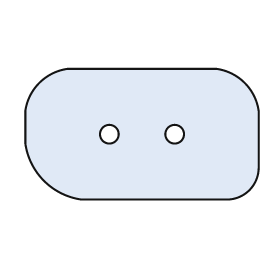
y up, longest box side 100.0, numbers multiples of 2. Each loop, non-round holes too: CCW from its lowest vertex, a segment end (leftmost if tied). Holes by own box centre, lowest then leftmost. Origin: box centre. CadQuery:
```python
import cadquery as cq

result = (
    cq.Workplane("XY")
    .moveTo(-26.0, -28.0)
    .lineTo(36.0, -28.0)
    .threePointArc((46.0, -24.0), (50.0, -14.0))
    .lineTo(50.0, 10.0)
    .threePointArc((44.0, 22.0), (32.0, 28.0))
    .lineTo(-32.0, 28.0)
    .threePointArc((-44.0, 22.0), (-50.0, 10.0))
    .lineTo(-50.0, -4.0)
    .threePointArc((-42.0, -20.0), (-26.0, -28.0))
    .close()
    .moveTo(-14.0, 0.0)
    .circle(4.0)
    .moveTo(14.0, 0.0)
    .circle(4.0)
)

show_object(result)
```